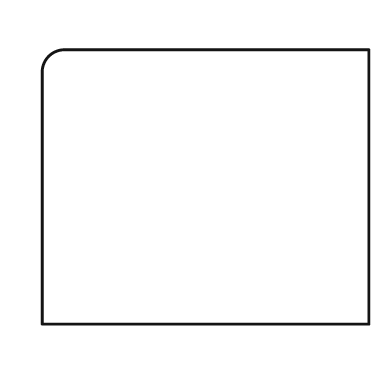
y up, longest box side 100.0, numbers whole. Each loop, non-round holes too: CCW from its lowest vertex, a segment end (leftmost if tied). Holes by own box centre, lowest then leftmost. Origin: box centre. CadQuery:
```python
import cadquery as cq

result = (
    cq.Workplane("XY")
    .moveTo(-50.0, -42.0)
    .lineTo(50.0, -42.0)
    .lineTo(50.0, 42.0)
    .lineTo(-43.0, 42.0)
    .threePointArc((-48.0, 40.0), (-50.0, 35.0))
    .close()
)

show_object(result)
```